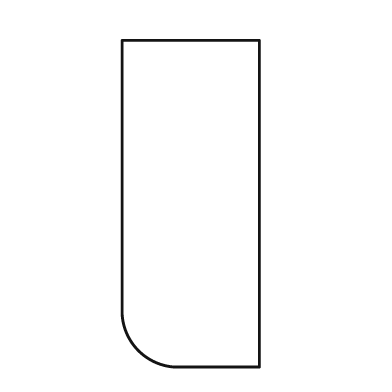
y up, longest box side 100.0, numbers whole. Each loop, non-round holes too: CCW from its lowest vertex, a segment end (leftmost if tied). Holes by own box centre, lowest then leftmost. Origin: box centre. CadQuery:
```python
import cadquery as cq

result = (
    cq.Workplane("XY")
    .moveTo(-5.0, -50.0)
    .lineTo(21.0, -50.0)
    .lineTo(21.0, 50.0)
    .lineTo(-21.0, 50.0)
    .lineTo(-21.0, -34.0)
    .threePointArc((-16.0, -45.0), (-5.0, -50.0))
    .close()
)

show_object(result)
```